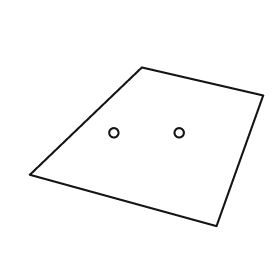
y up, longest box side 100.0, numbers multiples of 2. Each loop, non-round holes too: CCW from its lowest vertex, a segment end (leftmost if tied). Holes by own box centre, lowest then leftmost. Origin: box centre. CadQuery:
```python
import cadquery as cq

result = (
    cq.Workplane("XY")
    .moveTo(30.0, -34.0)
    .lineTo(50.0, 22.0)
    .lineTo(-2.0, 34.0)
    .lineTo(-50.0, -12.0)
    .close()
    .moveTo(-14.0, 6.0)
    .circle(2.0)
    .moveTo(14.0, 6.0)
    .circle(2.0)
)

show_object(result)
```